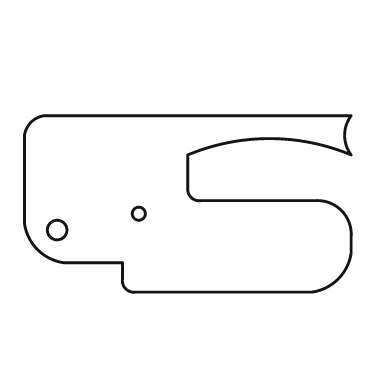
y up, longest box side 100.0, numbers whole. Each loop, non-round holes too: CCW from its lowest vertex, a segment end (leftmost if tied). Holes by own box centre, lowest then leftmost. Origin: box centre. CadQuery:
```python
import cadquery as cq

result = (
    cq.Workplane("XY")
    .moveTo(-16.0, -27.0)
    .lineTo(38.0, -27.0)
    .threePointArc((46.0, -23.0), (50.0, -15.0))
    .lineTo(50.0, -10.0)
    .threePointArc((47.0, -2.0), (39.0, 1.0))
    .lineTo(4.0, 1.0)
    .threePointArc((1.0, 2.0), (0.0, 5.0))
    .lineTo(0.0, 15.0)
    .threePointArc((25.0, 20.0), (50.0, 15.0))
    .threePointArc((48.0, 21.0), (50.0, 27.0))
    .lineTo(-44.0, 27.0)
    .threePointArc((-48.0, 25.0), (-50.0, 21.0))
    .lineTo(-50.0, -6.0)
    .threePointArc((-46.0, -14.0), (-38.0, -18.0))
    .lineTo(-20.0, -18.0)
    .lineTo(-20.0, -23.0)
    .threePointArc((-19.0, -26.0), (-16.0, -27.0))
    .close()
    .moveTo(-40.0, -8.0)
    .circle(3.0)
    .moveTo(-15.0, -3.0)
    .circle(2.0)
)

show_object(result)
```